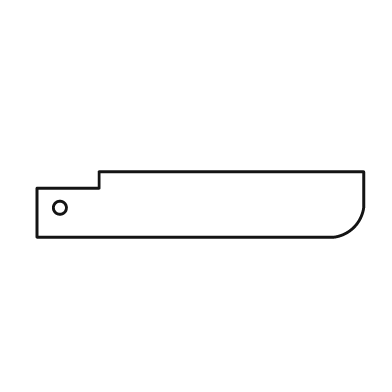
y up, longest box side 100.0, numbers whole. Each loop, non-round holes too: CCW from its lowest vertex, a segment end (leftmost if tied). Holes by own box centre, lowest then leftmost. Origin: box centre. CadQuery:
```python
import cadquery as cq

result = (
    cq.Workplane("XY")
    .moveTo(-50.0, -10.0)
    .lineTo(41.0, -10.0)
    .threePointArc((47.0, -7.0), (50.0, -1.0))
    .lineTo(50.0, 10.0)
    .lineTo(-31.0, 10.0)
    .lineTo(-31.0, 5.0)
    .lineTo(-50.0, 5.0)
    .close()
    .moveTo(-43.0, -1.0)
    .circle(2.0)
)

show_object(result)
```